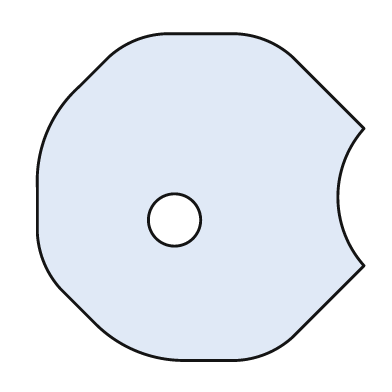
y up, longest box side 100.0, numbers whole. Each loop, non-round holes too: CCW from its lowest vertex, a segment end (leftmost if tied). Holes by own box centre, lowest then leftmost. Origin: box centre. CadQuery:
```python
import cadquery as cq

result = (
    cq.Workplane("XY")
    .moveTo(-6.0, -50.0)
    .lineTo(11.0, -50.0)
    .threePointArc((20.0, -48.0), (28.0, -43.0))
    .lineTo(50.0, -21.0)
    .threePointArc((42.0, 0.0), (50.0, 21.0))
    .lineTo(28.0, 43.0)
    .threePointArc((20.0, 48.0), (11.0, 50.0))
    .lineTo(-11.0, 50.0)
    .threePointArc((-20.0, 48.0), (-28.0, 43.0))
    .lineTo(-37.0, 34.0)
    .threePointArc((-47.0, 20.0), (-50.0, 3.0))
    .lineTo(-50.0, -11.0)
    .threePointArc((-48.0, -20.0), (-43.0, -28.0))
    .lineTo(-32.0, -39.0)
    .threePointArc((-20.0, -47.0), (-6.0, -50.0))
    .close()
    .moveTo(-8.0, -7.0)
    .circle(8.0)
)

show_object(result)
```